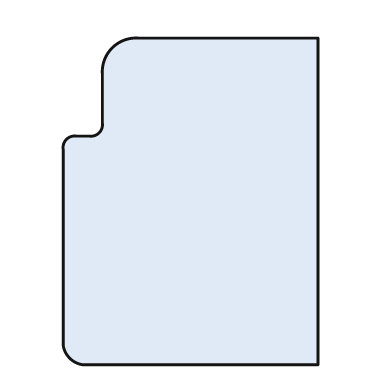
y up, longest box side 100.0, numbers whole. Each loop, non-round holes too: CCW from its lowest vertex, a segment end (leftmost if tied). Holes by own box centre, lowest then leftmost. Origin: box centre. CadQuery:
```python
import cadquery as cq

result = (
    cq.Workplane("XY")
    .moveTo(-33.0, -50.0)
    .lineTo(39.0, -50.0)
    .lineTo(39.0, 50.0)
    .lineTo(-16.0, 50.0)
    .threePointArc((-24.0, 47.0), (-27.0, 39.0))
    .lineTo(-27.0, 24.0)
    .threePointArc((-28.0, 21.0), (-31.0, 20.0))
    .lineTo(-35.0, 20.0)
    .threePointArc((-38.0, 19.0), (-39.0, 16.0))
    .lineTo(-39.0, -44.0)
    .threePointArc((-37.0, -48.0), (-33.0, -50.0))
    .close()
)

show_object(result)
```